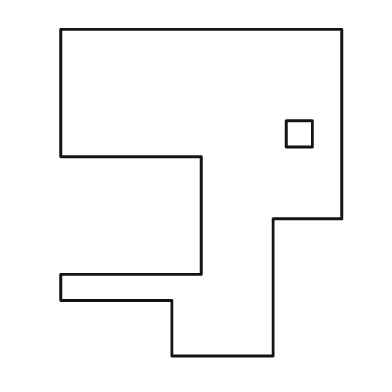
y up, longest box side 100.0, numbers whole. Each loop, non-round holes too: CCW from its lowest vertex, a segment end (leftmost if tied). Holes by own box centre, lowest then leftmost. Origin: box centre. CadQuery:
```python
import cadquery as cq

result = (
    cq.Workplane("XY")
    .moveTo(-9.0, -50.0)
    .lineTo(22.0, -50.0)
    .lineTo(22.0, -8.0)
    .lineTo(43.0, -8.0)
    .lineTo(43.0, 50.0)
    .lineTo(-43.0, 50.0)
    .lineTo(-43.0, 11.0)
    .lineTo(0.0, 11.0)
    .lineTo(0.0, -25.0)
    .lineTo(-43.0, -25.0)
    .lineTo(-43.0, -33.0)
    .lineTo(-9.0, -33.0)
    .close()
    .moveTo(26.0, 14.0)
    .lineTo(34.0, 14.0)
    .lineTo(34.0, 22.0)
    .lineTo(26.0, 22.0)
    .close()
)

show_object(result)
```